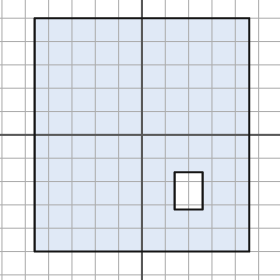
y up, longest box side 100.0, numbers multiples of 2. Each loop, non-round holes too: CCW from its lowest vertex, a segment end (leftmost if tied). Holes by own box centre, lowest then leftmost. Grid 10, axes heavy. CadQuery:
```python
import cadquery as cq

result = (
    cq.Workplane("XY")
    .moveTo(-46.0, -50.0)
    .lineTo(46.0, -50.0)
    .lineTo(46.0, 50.0)
    .lineTo(-46.0, 50.0)
    .close()
    .moveTo(14.0, -32.0)
    .lineTo(26.0, -32.0)
    .lineTo(26.0, -16.0)
    .lineTo(14.0, -16.0)
    .close()
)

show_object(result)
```